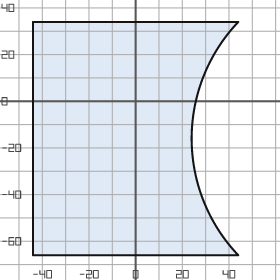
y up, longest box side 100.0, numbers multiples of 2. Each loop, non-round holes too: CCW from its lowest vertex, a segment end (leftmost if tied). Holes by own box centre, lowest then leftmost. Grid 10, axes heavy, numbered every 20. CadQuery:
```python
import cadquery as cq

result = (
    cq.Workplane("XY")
    .moveTo(-44.0, -66.0)
    .lineTo(44.0, -66.0)
    .threePointArc((24.0, -16.0), (44.0, 34.0))
    .lineTo(-44.0, 34.0)
    .close()
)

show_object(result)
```